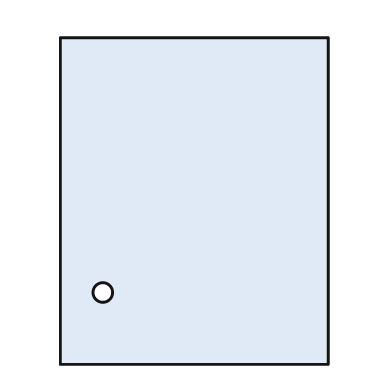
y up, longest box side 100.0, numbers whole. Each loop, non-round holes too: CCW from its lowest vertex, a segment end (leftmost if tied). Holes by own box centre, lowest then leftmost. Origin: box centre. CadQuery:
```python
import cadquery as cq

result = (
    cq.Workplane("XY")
    .moveTo(-41.0, -50.0)
    .lineTo(41.0, -50.0)
    .lineTo(41.0, 50.0)
    .lineTo(-41.0, 50.0)
    .close()
    .moveTo(-28.0, -28.0)
    .circle(3.0)
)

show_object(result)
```